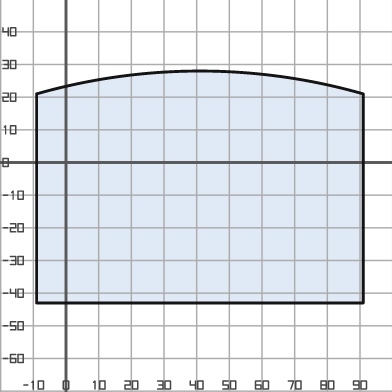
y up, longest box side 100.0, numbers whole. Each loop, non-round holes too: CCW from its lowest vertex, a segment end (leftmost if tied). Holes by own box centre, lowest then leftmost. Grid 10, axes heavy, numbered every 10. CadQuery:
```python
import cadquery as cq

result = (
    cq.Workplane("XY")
    .moveTo(-9.0, -43.0)
    .lineTo(91.0, -43.0)
    .lineTo(91.0, 21.0)
    .threePointArc((41.0, 28.0), (-9.0, 21.0))
    .close()
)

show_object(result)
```